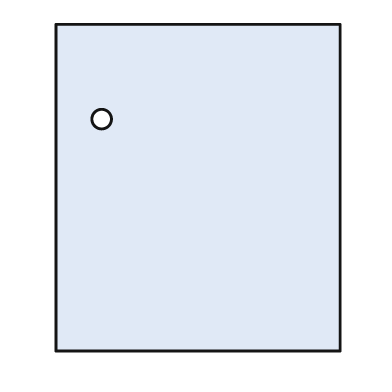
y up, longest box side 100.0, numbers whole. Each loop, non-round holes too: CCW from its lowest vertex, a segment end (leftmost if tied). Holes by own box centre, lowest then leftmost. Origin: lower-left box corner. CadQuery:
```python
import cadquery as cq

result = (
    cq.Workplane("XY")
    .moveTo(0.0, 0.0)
    .lineTo(87.0, 0.0)
    .lineTo(87.0, 100.0)
    .lineTo(0.0, 100.0)
    .close()
    .moveTo(14.0, 71.0)
    .circle(3.0)
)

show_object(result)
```